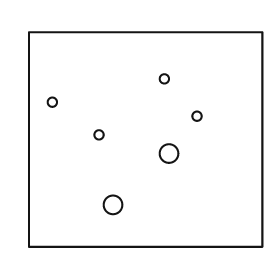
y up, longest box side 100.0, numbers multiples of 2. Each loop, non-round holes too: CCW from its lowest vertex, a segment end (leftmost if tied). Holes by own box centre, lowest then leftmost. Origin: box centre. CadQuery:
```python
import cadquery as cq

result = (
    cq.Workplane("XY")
    .moveTo(-50.0, -46.0)
    .lineTo(50.0, -46.0)
    .lineTo(50.0, 46.0)
    .lineTo(-50.0, 46.0)
    .close()
    .moveTo(-14.0, -28.0)
    .circle(4.0)
    .moveTo(10.0, -6.0)
    .circle(4.0)
    .moveTo(-20.0, 2.0)
    .circle(2.0)
    .moveTo(22.0, 10.0)
    .circle(2.0)
    .moveTo(-40.0, 16.0)
    .circle(2.0)
    .moveTo(8.0, 26.0)
    .circle(2.0)
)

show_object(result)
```